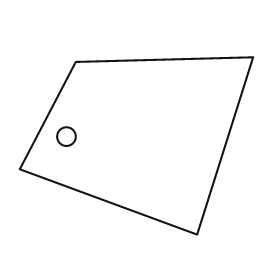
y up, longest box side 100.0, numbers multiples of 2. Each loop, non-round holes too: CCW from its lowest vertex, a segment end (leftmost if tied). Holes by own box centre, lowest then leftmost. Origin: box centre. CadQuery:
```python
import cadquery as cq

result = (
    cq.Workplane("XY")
    .moveTo(26.0, -38.0)
    .lineTo(50.0, 38.0)
    .lineTo(-26.0, 36.0)
    .lineTo(-50.0, -10.0)
    .close()
    .moveTo(-30.0, 4.0)
    .circle(4.0)
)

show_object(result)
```